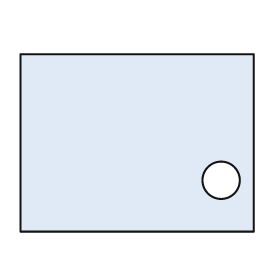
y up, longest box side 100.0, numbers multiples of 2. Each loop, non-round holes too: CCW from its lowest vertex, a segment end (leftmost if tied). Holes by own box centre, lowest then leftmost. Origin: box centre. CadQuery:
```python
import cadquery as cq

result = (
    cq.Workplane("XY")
    .moveTo(-50.0, -38.0)
    .lineTo(50.0, -38.0)
    .lineTo(50.0, 38.0)
    .lineTo(-50.0, 38.0)
    .close()
    .moveTo(36.0, -16.0)
    .circle(8.0)
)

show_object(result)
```